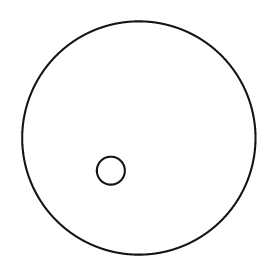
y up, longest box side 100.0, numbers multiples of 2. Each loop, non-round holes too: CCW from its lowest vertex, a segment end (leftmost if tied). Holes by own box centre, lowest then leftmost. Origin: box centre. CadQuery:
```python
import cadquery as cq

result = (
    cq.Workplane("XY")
    .moveTo(0.0, 0.0)
    .circle(50.0)
    .moveTo(-12.0, -14.0)
    .circle(6.0)
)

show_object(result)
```